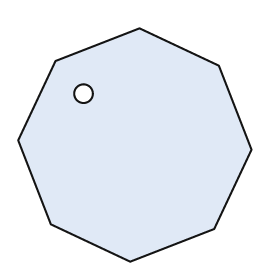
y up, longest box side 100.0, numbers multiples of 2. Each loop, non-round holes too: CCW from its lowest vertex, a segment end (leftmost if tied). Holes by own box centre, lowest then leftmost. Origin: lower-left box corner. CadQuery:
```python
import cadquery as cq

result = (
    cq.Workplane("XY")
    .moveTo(48.0, 0.0)
    .lineTo(84.0, 14.0)
    .lineTo(100.0, 48.0)
    .lineTo(86.0, 84.0)
    .lineTo(52.0, 100.0)
    .lineTo(16.0, 86.0)
    .lineTo(0.0, 52.0)
    .lineTo(14.0, 16.0)
    .close()
    .moveTo(28.0, 72.0)
    .circle(4.0)
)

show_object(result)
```